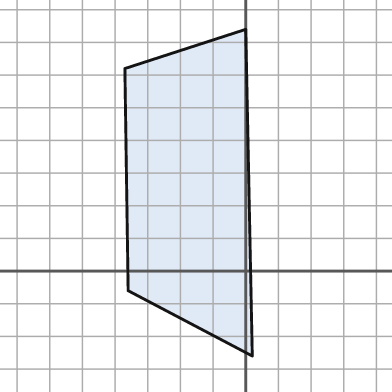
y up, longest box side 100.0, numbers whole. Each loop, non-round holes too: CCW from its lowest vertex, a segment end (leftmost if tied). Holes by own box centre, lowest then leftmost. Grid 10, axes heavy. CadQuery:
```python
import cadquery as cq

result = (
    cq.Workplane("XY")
    .moveTo(2.0, -26.0)
    .lineTo(0.0, 74.0)
    .lineTo(-37.0, 62.0)
    .lineTo(-36.0, -6.0)
    .close()
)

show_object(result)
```